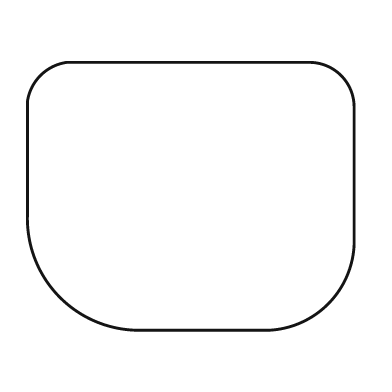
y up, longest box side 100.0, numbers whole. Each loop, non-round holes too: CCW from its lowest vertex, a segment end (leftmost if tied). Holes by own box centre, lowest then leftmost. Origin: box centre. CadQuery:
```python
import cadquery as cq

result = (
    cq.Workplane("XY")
    .moveTo(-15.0, -41.0)
    .lineTo(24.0, -41.0)
    .threePointArc((42.0, -33.0), (50.0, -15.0))
    .lineTo(50.0, 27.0)
    .threePointArc((46.0, 37.0), (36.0, 41.0))
    .lineTo(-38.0, 41.0)
    .threePointArc((-46.0, 37.0), (-50.0, 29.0))
    .lineTo(-50.0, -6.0)
    .threePointArc((-40.0, -31.0), (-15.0, -41.0))
    .close()
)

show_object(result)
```